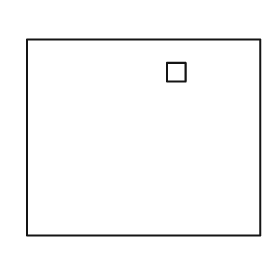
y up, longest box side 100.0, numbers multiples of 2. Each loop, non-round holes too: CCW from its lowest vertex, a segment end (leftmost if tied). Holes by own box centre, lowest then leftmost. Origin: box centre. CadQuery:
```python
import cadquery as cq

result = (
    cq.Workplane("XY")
    .moveTo(-50.0, -42.0)
    .lineTo(50.0, -42.0)
    .lineTo(50.0, 42.0)
    .lineTo(-50.0, 42.0)
    .close()
    .moveTo(10.0, 24.0)
    .lineTo(18.0, 24.0)
    .lineTo(18.0, 32.0)
    .lineTo(10.0, 32.0)
    .close()
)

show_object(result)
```